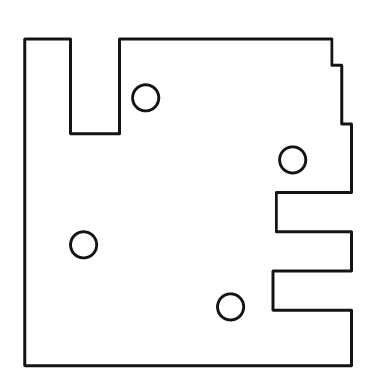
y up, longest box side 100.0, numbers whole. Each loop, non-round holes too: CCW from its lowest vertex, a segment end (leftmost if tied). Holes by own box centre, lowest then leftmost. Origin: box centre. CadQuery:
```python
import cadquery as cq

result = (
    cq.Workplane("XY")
    .moveTo(-50.0, -50.0)
    .lineTo(50.0, -50.0)
    .lineTo(50.0, -33.0)
    .lineTo(26.0, -33.0)
    .lineTo(26.0, -21.0)
    .lineTo(50.0, -21.0)
    .lineTo(50.0, -9.0)
    .lineTo(27.0, -9.0)
    .lineTo(27.0, 3.0)
    .lineTo(50.0, 3.0)
    .lineTo(50.0, 24.0)
    .lineTo(47.0, 24.0)
    .lineTo(47.0, 42.0)
    .lineTo(44.0, 42.0)
    .lineTo(44.0, 50.0)
    .lineTo(-21.0, 50.0)
    .lineTo(-21.0, 21.0)
    .lineTo(-36.0, 21.0)
    .lineTo(-36.0, 50.0)
    .lineTo(-50.0, 50.0)
    .close()
    .moveTo(13.0, -32.0)
    .circle(4.0)
    .moveTo(-32.0, -13.0)
    .circle(4.0)
    .moveTo(32.0, 13.0)
    .circle(4.0)
    .moveTo(-13.0, 32.0)
    .circle(4.0)
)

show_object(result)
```